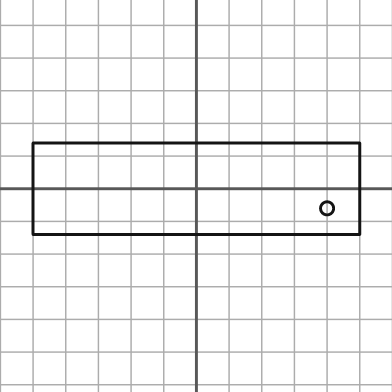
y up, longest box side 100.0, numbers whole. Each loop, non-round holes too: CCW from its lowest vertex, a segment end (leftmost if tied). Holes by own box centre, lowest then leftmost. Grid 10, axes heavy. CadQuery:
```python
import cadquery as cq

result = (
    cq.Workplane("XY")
    .moveTo(-50.0, -14.0)
    .lineTo(50.0, -14.0)
    .lineTo(50.0, 14.0)
    .lineTo(-50.0, 14.0)
    .close()
    .moveTo(40.0, -6.0)
    .circle(2.0)
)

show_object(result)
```